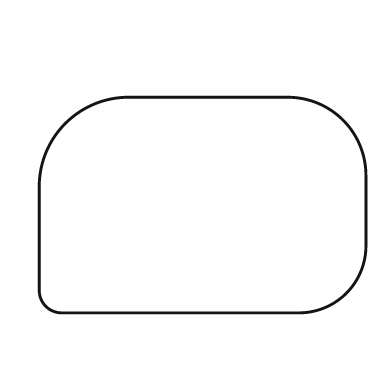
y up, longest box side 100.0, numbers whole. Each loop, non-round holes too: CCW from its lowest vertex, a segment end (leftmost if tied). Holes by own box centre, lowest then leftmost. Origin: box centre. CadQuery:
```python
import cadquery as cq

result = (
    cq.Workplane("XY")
    .moveTo(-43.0, -33.0)
    .lineTo(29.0, -33.0)
    .threePointArc((44.0, -27.0), (50.0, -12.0))
    .lineTo(50.0, 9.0)
    .threePointArc((43.0, 26.0), (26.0, 33.0))
    .lineTo(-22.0, 33.0)
    .threePointArc((-42.0, 25.0), (-50.0, 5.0))
    .lineTo(-50.0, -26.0)
    .threePointArc((-48.0, -31.0), (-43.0, -33.0))
    .close()
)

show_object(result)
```